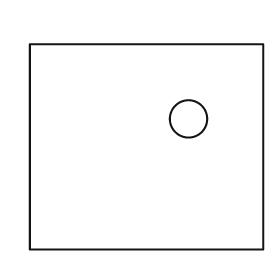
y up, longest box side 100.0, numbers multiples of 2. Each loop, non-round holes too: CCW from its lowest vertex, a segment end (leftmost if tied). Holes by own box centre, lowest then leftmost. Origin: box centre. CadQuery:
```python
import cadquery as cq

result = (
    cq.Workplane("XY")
    .moveTo(-50.0, -44.0)
    .lineTo(50.0, -44.0)
    .lineTo(50.0, 44.0)
    .lineTo(-50.0, 44.0)
    .close()
    .moveTo(18.0, 12.0)
    .circle(8.0)
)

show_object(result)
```